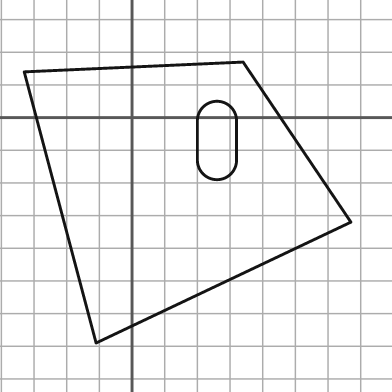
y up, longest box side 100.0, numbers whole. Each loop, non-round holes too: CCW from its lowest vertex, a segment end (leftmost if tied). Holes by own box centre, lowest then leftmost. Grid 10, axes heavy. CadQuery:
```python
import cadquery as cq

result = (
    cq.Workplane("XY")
    .moveTo(-11.0, -69.0)
    .lineTo(67.0, -32.0)
    .lineTo(34.0, 17.0)
    .lineTo(-33.0, 14.0)
    .close()
    .moveTo(20.0, -13.0)
    .threePointArc((26.0, -19.0), (32.0, -13.0))
    .lineTo(32.0, -1.0)
    .threePointArc((26.0, 5.0), (20.0, -1.0))
    .close()
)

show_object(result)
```